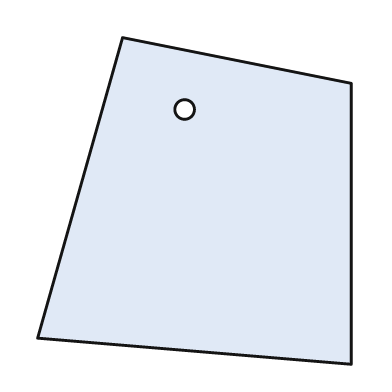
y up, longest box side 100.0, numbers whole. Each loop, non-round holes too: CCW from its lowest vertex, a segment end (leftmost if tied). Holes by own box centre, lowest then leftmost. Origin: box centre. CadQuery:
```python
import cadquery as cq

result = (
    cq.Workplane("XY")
    .moveTo(48.0, -50.0)
    .lineTo(48.0, 36.0)
    .lineTo(-22.0, 50.0)
    .lineTo(-48.0, -42.0)
    .close()
    .moveTo(-3.0, 28.0)
    .circle(3.0)
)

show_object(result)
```